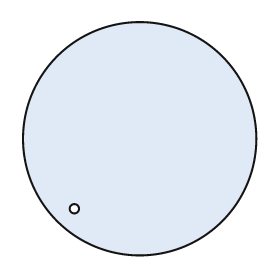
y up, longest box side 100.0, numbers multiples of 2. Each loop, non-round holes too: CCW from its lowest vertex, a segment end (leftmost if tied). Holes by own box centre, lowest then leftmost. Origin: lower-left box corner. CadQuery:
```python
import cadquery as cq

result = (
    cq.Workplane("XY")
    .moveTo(50.0, 50.0)
    .circle(50.0)
    .moveTo(22.0, 20.0)
    .circle(2.0)
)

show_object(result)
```